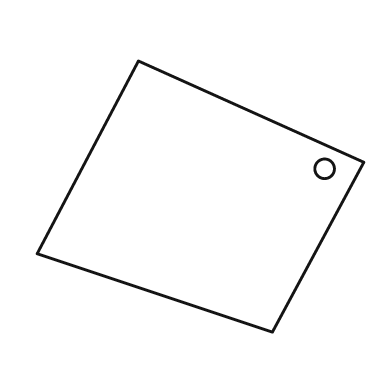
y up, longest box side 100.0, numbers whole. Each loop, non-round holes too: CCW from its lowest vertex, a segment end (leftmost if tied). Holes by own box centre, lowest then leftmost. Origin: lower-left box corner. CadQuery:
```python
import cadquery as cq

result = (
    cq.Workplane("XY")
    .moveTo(72.0, 0.0)
    .lineTo(100.0, 52.0)
    .lineTo(31.0, 83.0)
    .lineTo(0.0, 24.0)
    .close()
    .moveTo(88.0, 50.0)
    .circle(3.0)
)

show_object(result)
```